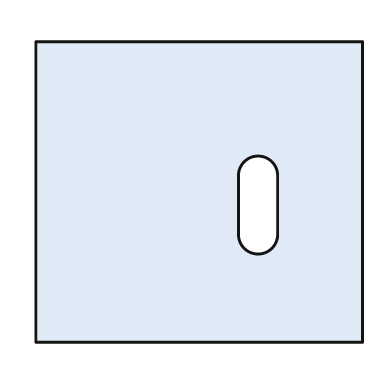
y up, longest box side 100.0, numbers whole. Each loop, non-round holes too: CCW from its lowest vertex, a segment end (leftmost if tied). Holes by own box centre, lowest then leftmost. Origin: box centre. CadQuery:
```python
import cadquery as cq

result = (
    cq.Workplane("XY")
    .moveTo(-50.0, -46.0)
    .lineTo(50.0, -46.0)
    .lineTo(50.0, 46.0)
    .lineTo(-50.0, 46.0)
    .close()
    .moveTo(12.0, -13.0)
    .threePointArc((18.0, -19.0), (24.0, -13.0))
    .lineTo(24.0, 5.0)
    .threePointArc((18.0, 11.0), (12.0, 5.0))
    .close()
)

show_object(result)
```